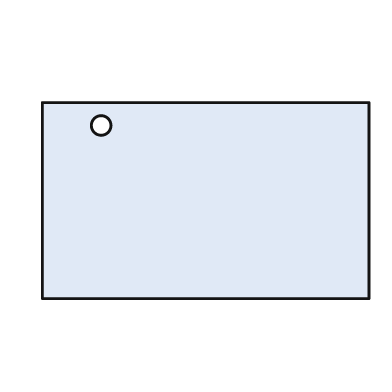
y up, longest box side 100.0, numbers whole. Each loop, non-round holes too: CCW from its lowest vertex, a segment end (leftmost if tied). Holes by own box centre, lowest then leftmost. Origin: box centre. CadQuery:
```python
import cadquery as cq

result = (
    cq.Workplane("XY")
    .moveTo(-50.0, -30.0)
    .lineTo(50.0, -30.0)
    .lineTo(50.0, 30.0)
    .lineTo(-50.0, 30.0)
    .close()
    .moveTo(-32.0, 23.0)
    .circle(3.0)
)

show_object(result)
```